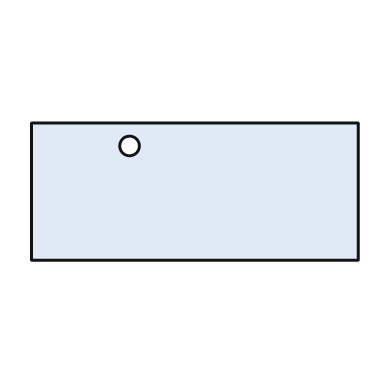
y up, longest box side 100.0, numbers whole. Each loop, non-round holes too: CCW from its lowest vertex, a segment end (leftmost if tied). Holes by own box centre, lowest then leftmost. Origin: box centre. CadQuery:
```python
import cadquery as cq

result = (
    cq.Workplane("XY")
    .moveTo(-50.0, -21.0)
    .lineTo(50.0, -21.0)
    .lineTo(50.0, 21.0)
    .lineTo(-50.0, 21.0)
    .close()
    .moveTo(-20.0, 14.0)
    .circle(3.0)
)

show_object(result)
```